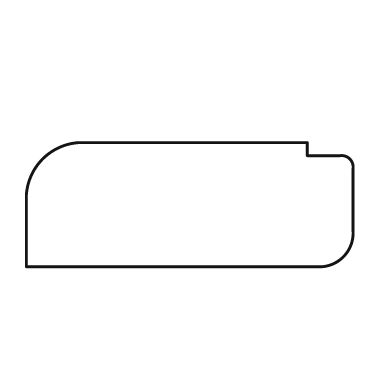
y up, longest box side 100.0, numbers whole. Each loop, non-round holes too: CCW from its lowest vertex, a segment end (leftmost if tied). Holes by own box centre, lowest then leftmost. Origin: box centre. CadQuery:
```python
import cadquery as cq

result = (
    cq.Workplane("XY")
    .moveTo(-50.0, -19.0)
    .lineTo(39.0, -19.0)
    .threePointArc((47.0, -16.0), (50.0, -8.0))
    .lineTo(50.0, 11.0)
    .threePointArc((49.0, 14.0), (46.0, 15.0))
    .lineTo(36.0, 15.0)
    .lineTo(36.0, 19.0)
    .lineTo(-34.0, 19.0)
    .threePointArc((-45.0, 14.0), (-50.0, 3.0))
    .close()
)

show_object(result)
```